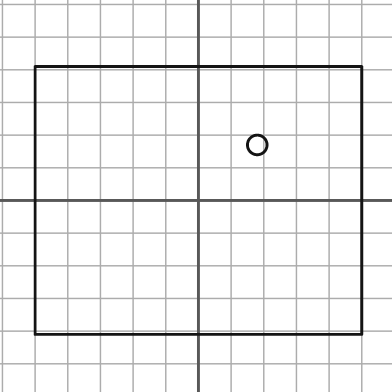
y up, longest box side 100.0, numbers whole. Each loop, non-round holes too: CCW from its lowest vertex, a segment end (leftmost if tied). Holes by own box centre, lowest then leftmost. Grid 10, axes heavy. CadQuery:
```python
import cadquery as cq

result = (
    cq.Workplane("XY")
    .moveTo(-50.0, -41.0)
    .lineTo(50.0, -41.0)
    .lineTo(50.0, 41.0)
    .lineTo(-50.0, 41.0)
    .close()
    .moveTo(18.0, 17.0)
    .circle(3.0)
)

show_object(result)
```